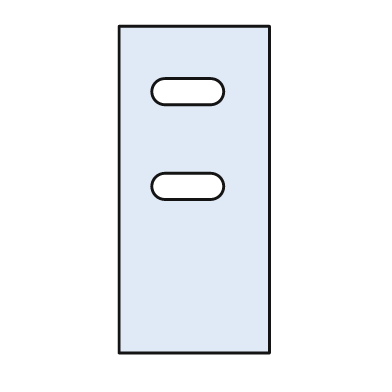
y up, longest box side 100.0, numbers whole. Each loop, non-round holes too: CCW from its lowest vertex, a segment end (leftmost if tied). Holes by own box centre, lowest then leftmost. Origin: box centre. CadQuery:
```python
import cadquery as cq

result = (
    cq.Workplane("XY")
    .moveTo(-23.0, -50.0)
    .lineTo(23.0, -50.0)
    .lineTo(23.0, 50.0)
    .lineTo(-23.0, 50.0)
    .close()
    .moveTo(-9.0, -3.0)
    .lineTo(5.0, -3.0)
    .threePointArc((9.0, 1.0), (5.0, 5.0))
    .lineTo(-9.0, 5.0)
    .threePointArc((-13.0, 1.0), (-9.0, -3.0))
    .close()
    .moveTo(-9.0, 26.0)
    .lineTo(5.0, 26.0)
    .threePointArc((9.0, 30.0), (5.0, 34.0))
    .lineTo(-9.0, 34.0)
    .threePointArc((-13.0, 30.0), (-9.0, 26.0))
    .close()
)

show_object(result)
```